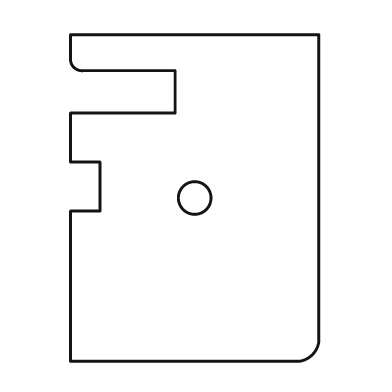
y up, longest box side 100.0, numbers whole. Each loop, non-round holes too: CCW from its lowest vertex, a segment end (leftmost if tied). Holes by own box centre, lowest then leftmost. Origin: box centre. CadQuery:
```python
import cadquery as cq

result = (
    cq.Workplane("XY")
    .moveTo(-38.0, -50.0)
    .lineTo(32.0, -50.0)
    .threePointArc((36.0, -48.0), (38.0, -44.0))
    .lineTo(38.0, 50.0)
    .lineTo(-38.0, 50.0)
    .lineTo(-38.0, 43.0)
    .threePointArc((-37.0, 40.0), (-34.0, 39.0))
    .lineTo(-6.0, 39.0)
    .lineTo(-6.0, 26.0)
    .lineTo(-38.0, 26.0)
    .lineTo(-38.0, 11.0)
    .lineTo(-29.0, 11.0)
    .lineTo(-29.0, -4.0)
    .lineTo(-38.0, -4.0)
    .close()
    .moveTo(0.0, 0.0)
    .circle(5.0)
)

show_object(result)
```